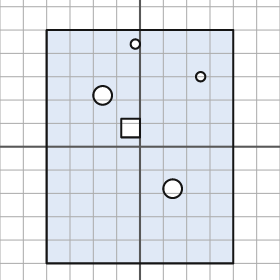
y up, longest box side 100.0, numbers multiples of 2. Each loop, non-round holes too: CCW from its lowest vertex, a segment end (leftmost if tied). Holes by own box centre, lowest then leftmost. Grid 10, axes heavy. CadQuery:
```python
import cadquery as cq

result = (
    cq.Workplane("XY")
    .moveTo(-40.0, -50.0)
    .lineTo(40.0, -50.0)
    .lineTo(40.0, 50.0)
    .lineTo(-40.0, 50.0)
    .close()
    .moveTo(14.0, -18.0)
    .circle(4.0)
    .moveTo(-8.0, 4.0)
    .lineTo(0.0, 4.0)
    .lineTo(0.0, 12.0)
    .lineTo(-8.0, 12.0)
    .close()
    .moveTo(-16.0, 22.0)
    .circle(4.0)
    .moveTo(26.0, 30.0)
    .circle(2.0)
    .moveTo(-2.0, 44.0)
    .circle(2.0)
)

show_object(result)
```